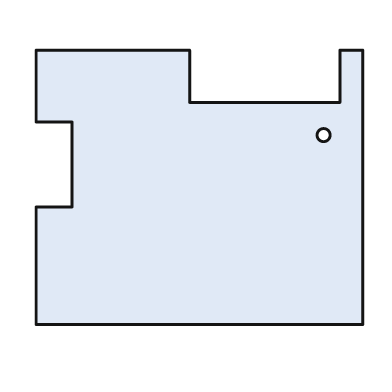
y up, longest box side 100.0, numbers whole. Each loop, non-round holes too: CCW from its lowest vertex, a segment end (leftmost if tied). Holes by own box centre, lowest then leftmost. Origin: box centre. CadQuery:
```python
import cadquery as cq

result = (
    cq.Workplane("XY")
    .moveTo(-50.0, -42.0)
    .lineTo(50.0, -42.0)
    .lineTo(50.0, 42.0)
    .lineTo(43.0, 42.0)
    .lineTo(43.0, 26.0)
    .lineTo(-3.0, 26.0)
    .lineTo(-3.0, 42.0)
    .lineTo(-50.0, 42.0)
    .lineTo(-50.0, 20.0)
    .lineTo(-39.0, 20.0)
    .lineTo(-39.0, -6.0)
    .lineTo(-50.0, -6.0)
    .close()
    .moveTo(38.0, 16.0)
    .circle(2.0)
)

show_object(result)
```